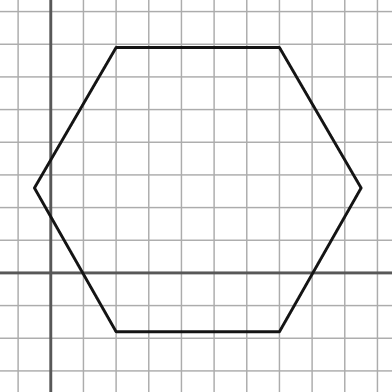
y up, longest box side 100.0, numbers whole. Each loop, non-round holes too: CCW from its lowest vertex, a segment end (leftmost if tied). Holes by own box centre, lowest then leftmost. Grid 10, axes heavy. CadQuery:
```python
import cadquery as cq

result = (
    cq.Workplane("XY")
    .moveTo(20.0, -18.0)
    .lineTo(70.0, -18.0)
    .lineTo(95.0, 26.0)
    .lineTo(70.0, 69.0)
    .lineTo(20.0, 69.0)
    .lineTo(-5.0, 26.0)
    .close()
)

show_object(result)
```